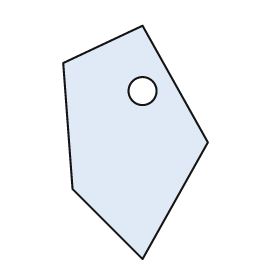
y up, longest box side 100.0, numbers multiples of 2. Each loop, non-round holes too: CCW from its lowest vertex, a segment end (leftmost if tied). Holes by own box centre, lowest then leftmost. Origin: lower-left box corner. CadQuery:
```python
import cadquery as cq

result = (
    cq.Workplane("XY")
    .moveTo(34.0, 0.0)
    .lineTo(62.0, 50.0)
    .lineTo(34.0, 100.0)
    .lineTo(0.0, 84.0)
    .lineTo(4.0, 30.0)
    .close()
    .moveTo(34.0, 72.0)
    .circle(6.0)
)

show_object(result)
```